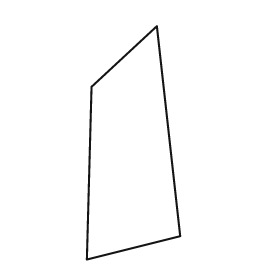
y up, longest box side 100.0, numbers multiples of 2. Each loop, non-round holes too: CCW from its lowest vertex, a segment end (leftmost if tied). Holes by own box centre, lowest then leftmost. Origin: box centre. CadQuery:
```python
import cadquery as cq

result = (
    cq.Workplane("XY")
    .moveTo(-20.0, -50.0)
    .lineTo(20.0, -40.0)
    .lineTo(10.0, 50.0)
    .lineTo(-18.0, 24.0)
    .close()
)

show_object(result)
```